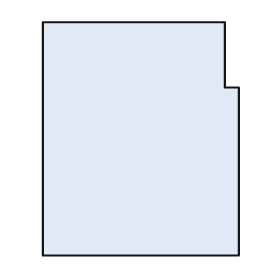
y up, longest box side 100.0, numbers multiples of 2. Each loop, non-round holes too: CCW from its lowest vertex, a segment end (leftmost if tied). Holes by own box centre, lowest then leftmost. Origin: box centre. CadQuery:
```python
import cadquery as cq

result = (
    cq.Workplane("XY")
    .moveTo(-42.0, -50.0)
    .lineTo(42.0, -50.0)
    .lineTo(42.0, 22.0)
    .lineTo(36.0, 22.0)
    .lineTo(36.0, 50.0)
    .lineTo(-42.0, 50.0)
    .close()
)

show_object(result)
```